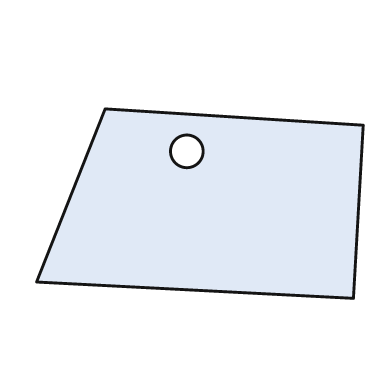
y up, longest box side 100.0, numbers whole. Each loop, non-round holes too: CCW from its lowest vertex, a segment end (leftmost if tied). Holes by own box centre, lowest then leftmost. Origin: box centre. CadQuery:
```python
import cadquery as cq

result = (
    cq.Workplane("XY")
    .moveTo(47.0, -29.0)
    .lineTo(50.0, 24.0)
    .lineTo(-29.0, 29.0)
    .lineTo(-50.0, -24.0)
    .close()
    .moveTo(-4.0, 16.0)
    .circle(5.0)
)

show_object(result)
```